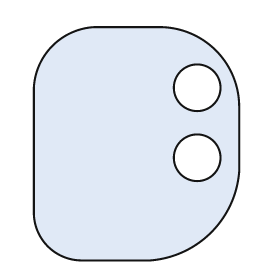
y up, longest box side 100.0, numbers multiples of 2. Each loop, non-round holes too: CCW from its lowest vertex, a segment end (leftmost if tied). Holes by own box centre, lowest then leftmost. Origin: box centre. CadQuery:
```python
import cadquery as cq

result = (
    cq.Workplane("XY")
    .moveTo(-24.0, -50.0)
    .lineTo(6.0, -50.0)
    .threePointArc((32.0, -38.0), (44.0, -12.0))
    .lineTo(44.0, 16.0)
    .threePointArc((34.0, 40.0), (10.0, 50.0))
    .lineTo(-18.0, 50.0)
    .threePointArc((-36.0, 42.0), (-44.0, 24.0))
    .lineTo(-44.0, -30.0)
    .threePointArc((-38.0, -44.0), (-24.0, -50.0))
    .close()
    .moveTo(26.0, -6.0)
    .circle(10.0)
    .moveTo(26.0, 24.0)
    .circle(10.0)
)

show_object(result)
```